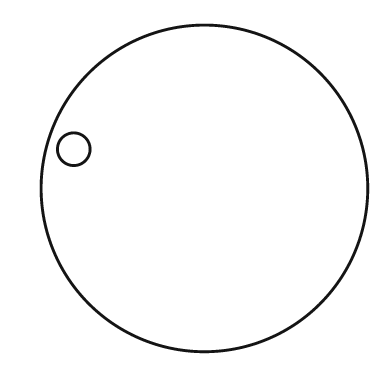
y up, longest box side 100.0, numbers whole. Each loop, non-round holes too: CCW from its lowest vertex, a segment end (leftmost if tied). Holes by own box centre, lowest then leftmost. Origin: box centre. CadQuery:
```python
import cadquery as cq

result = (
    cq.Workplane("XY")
    .moveTo(0.0, 0.0)
    .circle(50.0)
    .moveTo(-40.0, 12.0)
    .circle(5.0)
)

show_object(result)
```